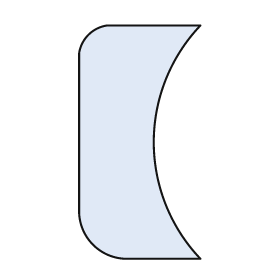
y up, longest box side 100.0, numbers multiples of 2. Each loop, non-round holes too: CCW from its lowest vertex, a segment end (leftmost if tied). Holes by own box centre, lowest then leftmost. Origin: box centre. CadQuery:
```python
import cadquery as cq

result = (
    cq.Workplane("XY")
    .moveTo(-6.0, -50.0)
    .lineTo(26.0, -50.0)
    .threePointArc((6.0, 0.0), (26.0, 50.0))
    .lineTo(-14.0, 50.0)
    .threePointArc((-22.0, 46.0), (-26.0, 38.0))
    .lineTo(-26.0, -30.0)
    .threePointArc((-20.0, -44.0), (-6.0, -50.0))
    .close()
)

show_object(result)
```